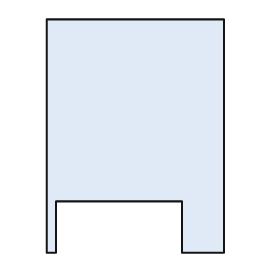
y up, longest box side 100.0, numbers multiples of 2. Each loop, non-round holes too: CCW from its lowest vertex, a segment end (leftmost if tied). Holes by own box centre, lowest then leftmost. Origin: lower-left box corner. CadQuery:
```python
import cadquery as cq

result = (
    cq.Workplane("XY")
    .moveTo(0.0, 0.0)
    .lineTo(4.0, 0.0)
    .lineTo(4.0, 22.0)
    .lineTo(58.0, 22.0)
    .lineTo(58.0, 0.0)
    .lineTo(76.0, 0.0)
    .lineTo(76.0, 100.0)
    .lineTo(0.0, 100.0)
    .close()
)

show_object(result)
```